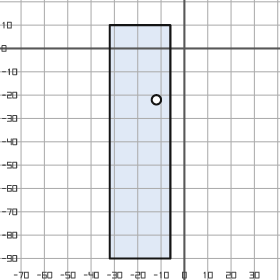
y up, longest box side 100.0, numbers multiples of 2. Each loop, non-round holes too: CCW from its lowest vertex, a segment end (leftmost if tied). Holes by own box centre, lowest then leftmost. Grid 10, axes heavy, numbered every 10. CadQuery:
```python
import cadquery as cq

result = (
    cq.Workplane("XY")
    .moveTo(-32.0, -90.0)
    .lineTo(-6.0, -90.0)
    .lineTo(-6.0, 10.0)
    .lineTo(-32.0, 10.0)
    .close()
    .moveTo(-12.0, -22.0)
    .circle(2.0)
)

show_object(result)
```